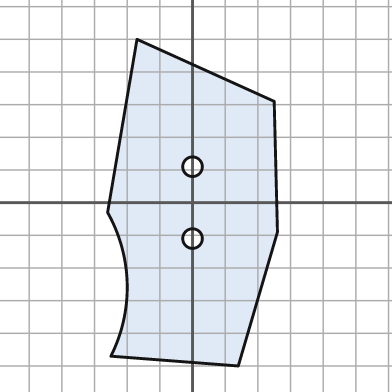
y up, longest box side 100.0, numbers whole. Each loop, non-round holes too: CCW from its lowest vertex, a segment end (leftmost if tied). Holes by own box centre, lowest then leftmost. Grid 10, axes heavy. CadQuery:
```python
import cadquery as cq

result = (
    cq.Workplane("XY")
    .moveTo(14.0, -50.0)
    .lineTo(26.0, -9.0)
    .lineTo(25.0, 31.0)
    .lineTo(-17.0, 50.0)
    .lineTo(-26.0, -3.0)
    .threePointArc((-20.0, -25.0), (-25.0, -47.0))
    .close()
    .moveTo(0.0, -11.0)
    .circle(3.0)
    .moveTo(0.0, 11.0)
    .circle(3.0)
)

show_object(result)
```